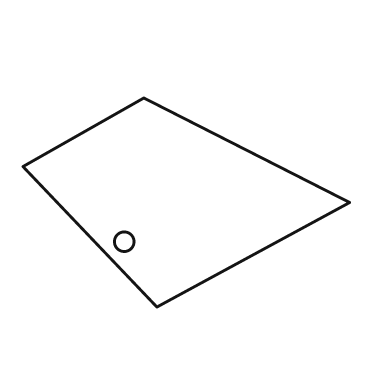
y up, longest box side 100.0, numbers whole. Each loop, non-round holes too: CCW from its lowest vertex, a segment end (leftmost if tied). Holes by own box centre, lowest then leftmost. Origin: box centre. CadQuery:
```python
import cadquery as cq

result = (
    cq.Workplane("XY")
    .moveTo(-9.0, -32.0)
    .lineTo(50.0, 0.0)
    .lineTo(-13.0, 32.0)
    .lineTo(-50.0, 11.0)
    .close()
    .moveTo(-19.0, -12.0)
    .circle(3.0)
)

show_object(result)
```